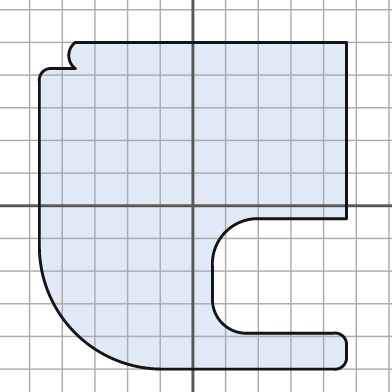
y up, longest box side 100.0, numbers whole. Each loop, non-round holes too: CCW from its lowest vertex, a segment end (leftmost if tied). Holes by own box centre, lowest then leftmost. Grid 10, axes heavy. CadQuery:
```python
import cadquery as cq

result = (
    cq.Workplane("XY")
    .moveTo(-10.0, -50.0)
    .lineTo(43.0, -50.0)
    .threePointArc((46.0, -49.0), (47.0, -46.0))
    .lineTo(47.0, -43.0)
    .threePointArc((46.0, -40.0), (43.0, -39.0))
    .lineTo(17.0, -39.0)
    .threePointArc((9.0, -36.0), (6.0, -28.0))
    .lineTo(6.0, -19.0)
    .threePointArc((10.0, -8.0), (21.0, -4.0))
    .lineTo(47.0, -4.0)
    .lineTo(47.0, 50.0)
    .lineTo(-36.0, 50.0)
    .threePointArc((-38.0, 46.0), (-36.0, 42.0))
    .lineTo(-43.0, 42.0)
    .threePointArc((-46.0, 41.0), (-47.0, 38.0))
    .lineTo(-47.0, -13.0)
    .threePointArc((-36.0, -39.0), (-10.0, -50.0))
    .close()
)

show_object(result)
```